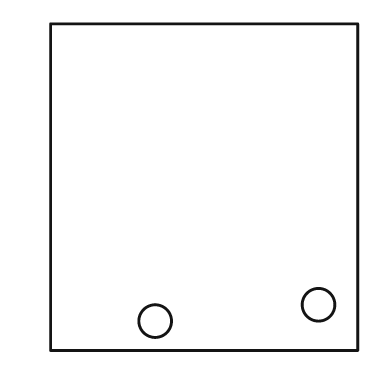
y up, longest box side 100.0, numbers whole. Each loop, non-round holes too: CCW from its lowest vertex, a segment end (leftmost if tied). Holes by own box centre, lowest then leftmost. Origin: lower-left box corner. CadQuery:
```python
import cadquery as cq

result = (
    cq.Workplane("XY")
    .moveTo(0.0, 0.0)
    .lineTo(94.0, 0.0)
    .lineTo(94.0, 100.0)
    .lineTo(0.0, 100.0)
    .close()
    .moveTo(32.0, 9.0)
    .circle(5.0)
    .moveTo(82.0, 14.0)
    .circle(5.0)
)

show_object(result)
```